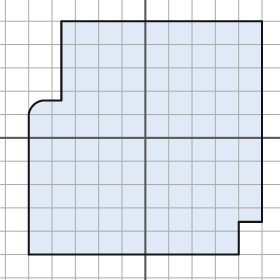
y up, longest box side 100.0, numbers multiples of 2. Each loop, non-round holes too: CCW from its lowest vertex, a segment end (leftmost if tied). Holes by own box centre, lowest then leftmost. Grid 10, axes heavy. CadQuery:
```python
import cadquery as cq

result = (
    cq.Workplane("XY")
    .moveTo(-50.0, -50.0)
    .lineTo(40.0, -50.0)
    .lineTo(40.0, -36.0)
    .lineTo(50.0, -36.0)
    .lineTo(50.0, 50.0)
    .lineTo(-36.0, 50.0)
    .lineTo(-36.0, 16.0)
    .lineTo(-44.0, 16.0)
    .threePointArc((-48.0, 14.0), (-50.0, 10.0))
    .close()
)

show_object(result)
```